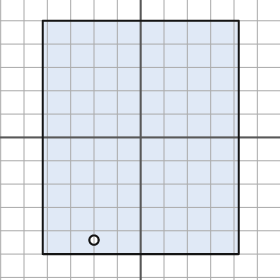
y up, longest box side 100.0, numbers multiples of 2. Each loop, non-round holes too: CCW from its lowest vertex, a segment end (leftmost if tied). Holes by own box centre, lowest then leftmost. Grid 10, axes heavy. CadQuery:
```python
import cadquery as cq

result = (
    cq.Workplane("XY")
    .moveTo(-42.0, -50.0)
    .lineTo(42.0, -50.0)
    .lineTo(42.0, 50.0)
    .lineTo(-42.0, 50.0)
    .close()
    .moveTo(-20.0, -44.0)
    .circle(2.0)
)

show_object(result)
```